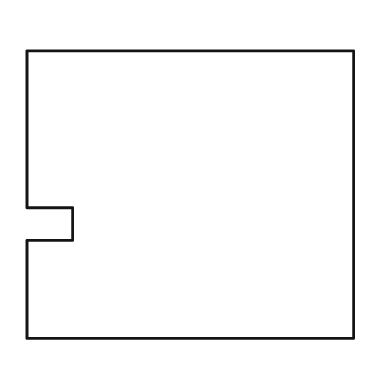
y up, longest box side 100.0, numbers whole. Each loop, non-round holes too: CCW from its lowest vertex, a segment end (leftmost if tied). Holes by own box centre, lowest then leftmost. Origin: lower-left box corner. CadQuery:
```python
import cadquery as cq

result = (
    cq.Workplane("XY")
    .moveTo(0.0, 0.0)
    .lineTo(100.0, 0.0)
    .lineTo(100.0, 88.0)
    .lineTo(0.0, 88.0)
    .lineTo(0.0, 40.0)
    .lineTo(14.0, 40.0)
    .lineTo(14.0, 30.0)
    .lineTo(0.0, 30.0)
    .close()
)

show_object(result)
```